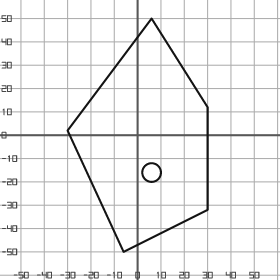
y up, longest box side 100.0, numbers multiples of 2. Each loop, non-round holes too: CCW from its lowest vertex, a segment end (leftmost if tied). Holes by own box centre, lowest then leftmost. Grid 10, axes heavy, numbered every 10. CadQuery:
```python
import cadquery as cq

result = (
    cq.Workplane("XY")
    .moveTo(-6.0, -50.0)
    .lineTo(30.0, -32.0)
    .lineTo(30.0, 12.0)
    .lineTo(6.0, 50.0)
    .lineTo(-30.0, 2.0)
    .close()
    .moveTo(6.0, -16.0)
    .circle(4.0)
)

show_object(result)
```